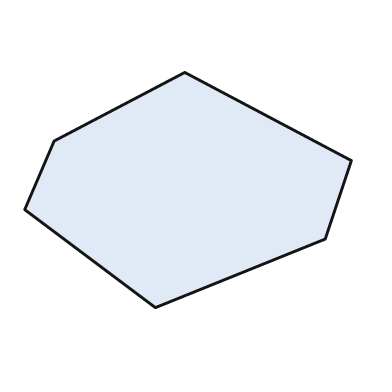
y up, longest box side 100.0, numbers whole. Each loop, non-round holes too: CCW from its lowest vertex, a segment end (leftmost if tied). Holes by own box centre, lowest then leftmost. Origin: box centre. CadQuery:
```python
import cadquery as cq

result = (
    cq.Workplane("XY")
    .moveTo(-10.0, -36.0)
    .lineTo(42.0, -15.0)
    .lineTo(50.0, 9.0)
    .lineTo(-1.0, 36.0)
    .lineTo(-41.0, 15.0)
    .lineTo(-50.0, -6.0)
    .close()
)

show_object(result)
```